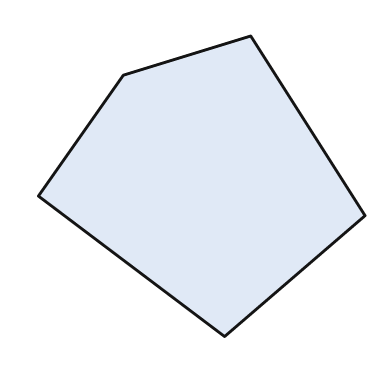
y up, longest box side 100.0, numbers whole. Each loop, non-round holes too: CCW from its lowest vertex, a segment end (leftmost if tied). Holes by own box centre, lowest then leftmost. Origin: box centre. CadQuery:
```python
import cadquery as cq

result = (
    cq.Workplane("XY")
    .moveTo(7.0, -46.0)
    .lineTo(50.0, -9.0)
    .lineTo(15.0, 46.0)
    .lineTo(-24.0, 34.0)
    .lineTo(-50.0, -3.0)
    .close()
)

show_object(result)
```